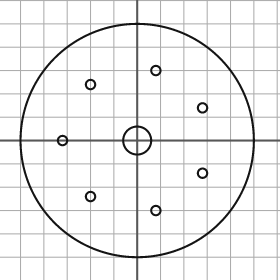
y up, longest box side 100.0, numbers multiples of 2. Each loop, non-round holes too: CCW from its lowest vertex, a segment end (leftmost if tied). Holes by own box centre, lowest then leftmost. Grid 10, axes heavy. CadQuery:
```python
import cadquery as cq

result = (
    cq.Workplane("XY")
    .moveTo(0.0, 0.0)
    .circle(50.0)
    .moveTo(8.0, -30.0)
    .circle(2.0)
    .moveTo(-20.0, -24.0)
    .circle(2.0)
    .moveTo(28.0, -14.0)
    .circle(2.0)
    .moveTo(-32.0, 0.0)
    .circle(2.0)
    .moveTo(0.0, 0.0)
    .circle(6.0)
    .moveTo(28.0, 14.0)
    .circle(2.0)
    .moveTo(-20.0, 24.0)
    .circle(2.0)
    .moveTo(8.0, 30.0)
    .circle(2.0)
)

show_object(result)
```